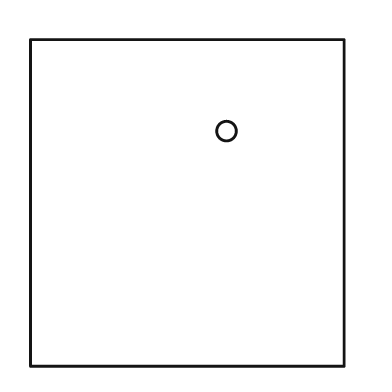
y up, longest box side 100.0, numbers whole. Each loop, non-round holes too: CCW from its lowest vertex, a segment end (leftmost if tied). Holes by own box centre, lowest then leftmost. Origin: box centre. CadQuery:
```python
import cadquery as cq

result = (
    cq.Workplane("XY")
    .moveTo(-48.0, -50.0)
    .lineTo(48.0, -50.0)
    .lineTo(48.0, 50.0)
    .lineTo(-48.0, 50.0)
    .close()
    .moveTo(12.0, 22.0)
    .circle(3.0)
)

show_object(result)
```